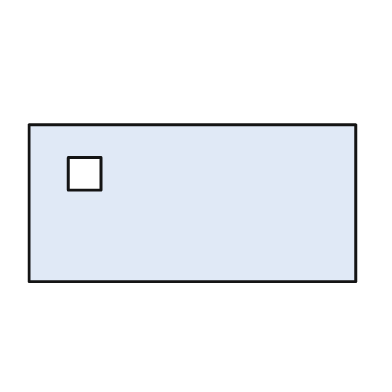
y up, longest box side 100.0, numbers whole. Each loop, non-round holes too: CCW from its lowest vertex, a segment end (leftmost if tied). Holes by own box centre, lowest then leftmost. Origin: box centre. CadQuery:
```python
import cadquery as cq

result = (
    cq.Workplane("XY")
    .moveTo(-50.0, -24.0)
    .lineTo(50.0, -24.0)
    .lineTo(50.0, 24.0)
    .lineTo(-50.0, 24.0)
    .close()
    .moveTo(-38.0, 4.0)
    .lineTo(-28.0, 4.0)
    .lineTo(-28.0, 14.0)
    .lineTo(-38.0, 14.0)
    .close()
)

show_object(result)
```